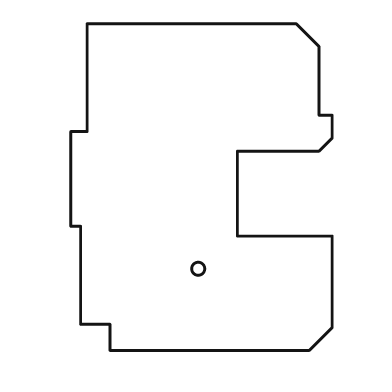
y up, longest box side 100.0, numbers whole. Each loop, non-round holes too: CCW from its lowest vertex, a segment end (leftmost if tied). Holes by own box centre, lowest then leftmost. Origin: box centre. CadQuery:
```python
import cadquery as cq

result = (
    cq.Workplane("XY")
    .moveTo(-28.0, -50.0)
    .lineTo(33.0, -50.0)
    .lineTo(40.0, -43.0)
    .lineTo(40.0, -15.0)
    .lineTo(11.0, -15.0)
    .lineTo(11.0, 11.0)
    .lineTo(36.0, 11.0)
    .lineTo(40.0, 15.0)
    .lineTo(40.0, 22.0)
    .lineTo(36.0, 22.0)
    .lineTo(36.0, 43.0)
    .lineTo(29.0, 50.0)
    .lineTo(-35.0, 50.0)
    .lineTo(-35.0, 17.0)
    .lineTo(-40.0, 17.0)
    .lineTo(-40.0, -12.0)
    .lineTo(-37.0, -12.0)
    .lineTo(-37.0, -42.0)
    .lineTo(-28.0, -42.0)
    .close()
    .moveTo(-1.0, -25.0)
    .circle(2.0)
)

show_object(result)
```